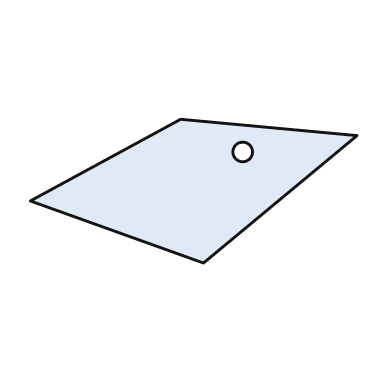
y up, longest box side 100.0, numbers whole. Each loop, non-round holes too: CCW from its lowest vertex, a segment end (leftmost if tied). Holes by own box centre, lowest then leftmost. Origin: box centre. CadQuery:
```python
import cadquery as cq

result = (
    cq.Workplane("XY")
    .moveTo(3.0, -22.0)
    .lineTo(50.0, 17.0)
    .lineTo(-4.0, 22.0)
    .lineTo(-50.0, -3.0)
    .close()
    .moveTo(15.0, 12.0)
    .circle(3.0)
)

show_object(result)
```